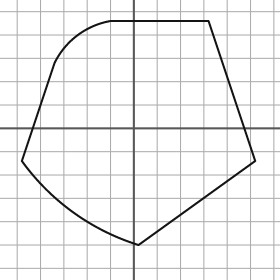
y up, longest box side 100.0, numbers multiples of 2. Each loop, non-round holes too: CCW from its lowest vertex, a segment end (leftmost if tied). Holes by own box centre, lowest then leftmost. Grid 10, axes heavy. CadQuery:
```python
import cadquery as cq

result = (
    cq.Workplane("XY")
    .moveTo(2.0, -50.0)
    .lineTo(52.0, -14.0)
    .lineTo(32.0, 46.0)
    .lineTo(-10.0, 46.0)
    .threePointArc((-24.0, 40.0), (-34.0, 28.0))
    .lineTo(-48.0, -14.0)
    .threePointArc((-26.0, -36.0), (2.0, -50.0))
    .close()
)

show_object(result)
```